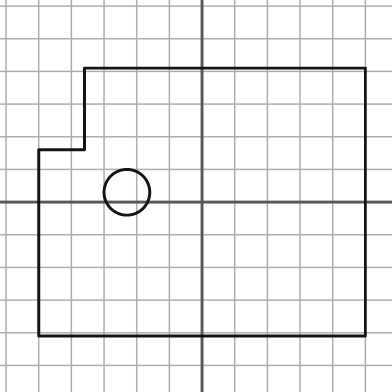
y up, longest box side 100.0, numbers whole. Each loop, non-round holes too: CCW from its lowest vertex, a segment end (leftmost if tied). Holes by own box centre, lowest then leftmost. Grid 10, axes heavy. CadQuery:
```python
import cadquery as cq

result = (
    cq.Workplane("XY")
    .moveTo(-50.0, -41.0)
    .lineTo(50.0, -41.0)
    .lineTo(50.0, 41.0)
    .lineTo(-36.0, 41.0)
    .lineTo(-36.0, 16.0)
    .lineTo(-50.0, 16.0)
    .close()
    .moveTo(-23.0, 3.0)
    .circle(7.0)
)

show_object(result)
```